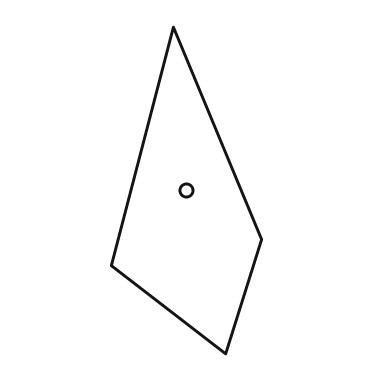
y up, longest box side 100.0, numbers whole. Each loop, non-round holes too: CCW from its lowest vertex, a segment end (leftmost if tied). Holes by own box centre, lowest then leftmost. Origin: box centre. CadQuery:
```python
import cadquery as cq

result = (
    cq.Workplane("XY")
    .moveTo(12.0, -50.0)
    .lineTo(23.0, -15.0)
    .lineTo(-4.0, 50.0)
    .lineTo(-23.0, -23.0)
    .close()
    .moveTo(0.0, 0.0)
    .circle(2.0)
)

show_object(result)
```